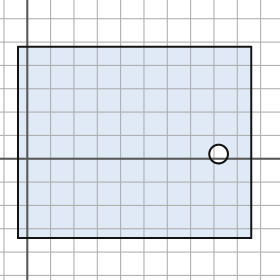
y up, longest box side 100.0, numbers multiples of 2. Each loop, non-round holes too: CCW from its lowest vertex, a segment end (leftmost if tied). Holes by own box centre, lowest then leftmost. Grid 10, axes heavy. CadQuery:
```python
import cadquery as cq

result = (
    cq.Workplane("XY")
    .moveTo(-4.0, -34.0)
    .lineTo(96.0, -34.0)
    .lineTo(96.0, 48.0)
    .lineTo(-4.0, 48.0)
    .close()
    .moveTo(82.0, 2.0)
    .circle(4.0)
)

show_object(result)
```